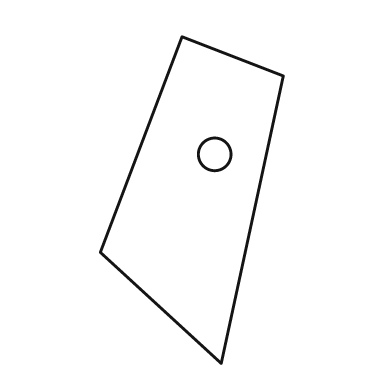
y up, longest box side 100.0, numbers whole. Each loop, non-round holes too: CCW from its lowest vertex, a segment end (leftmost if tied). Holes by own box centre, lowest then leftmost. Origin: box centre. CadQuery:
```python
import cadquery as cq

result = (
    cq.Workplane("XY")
    .moveTo(9.0, -50.0)
    .lineTo(28.0, 38.0)
    .lineTo(-3.0, 50.0)
    .lineTo(-28.0, -16.0)
    .close()
    .moveTo(7.0, 14.0)
    .circle(5.0)
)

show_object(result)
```